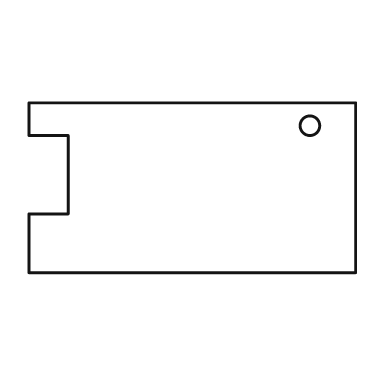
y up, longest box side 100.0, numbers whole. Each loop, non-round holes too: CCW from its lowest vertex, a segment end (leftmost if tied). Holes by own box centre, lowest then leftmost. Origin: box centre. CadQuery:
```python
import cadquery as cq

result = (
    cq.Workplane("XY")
    .moveTo(-50.0, -26.0)
    .lineTo(50.0, -26.0)
    .lineTo(50.0, 26.0)
    .lineTo(-50.0, 26.0)
    .lineTo(-50.0, 16.0)
    .lineTo(-38.0, 16.0)
    .lineTo(-38.0, -8.0)
    .lineTo(-50.0, -8.0)
    .close()
    .moveTo(36.0, 19.0)
    .circle(3.0)
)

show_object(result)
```